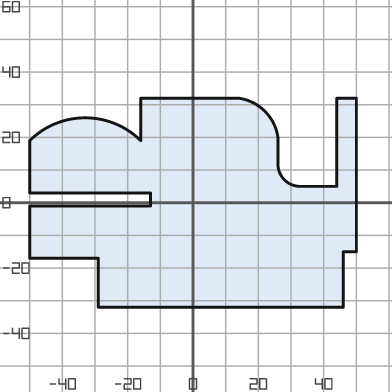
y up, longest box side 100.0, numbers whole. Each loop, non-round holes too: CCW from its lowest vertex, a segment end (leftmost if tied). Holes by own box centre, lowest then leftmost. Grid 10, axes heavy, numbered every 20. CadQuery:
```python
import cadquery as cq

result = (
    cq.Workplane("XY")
    .moveTo(-29.0, -32.0)
    .lineTo(46.0, -32.0)
    .lineTo(46.0, -15.0)
    .lineTo(50.0, -15.0)
    .lineTo(50.0, 32.0)
    .lineTo(44.0, 32.0)
    .lineTo(44.0, 5.0)
    .lineTo(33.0, 5.0)
    .threePointArc((28.0, 7.0), (26.0, 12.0))
    .lineTo(26.0, 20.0)
    .threePointArc((22.0, 28.0), (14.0, 32.0))
    .lineTo(-16.0, 32.0)
    .lineTo(-16.0, 19.0)
    .threePointArc((-33.0, 26.0), (-50.0, 19.0))
    .lineTo(-50.0, 3.0)
    .lineTo(-13.0, 3.0)
    .lineTo(-13.0, -1.0)
    .lineTo(-50.0, -1.0)
    .lineTo(-50.0, -17.0)
    .lineTo(-29.0, -17.0)
    .close()
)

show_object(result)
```